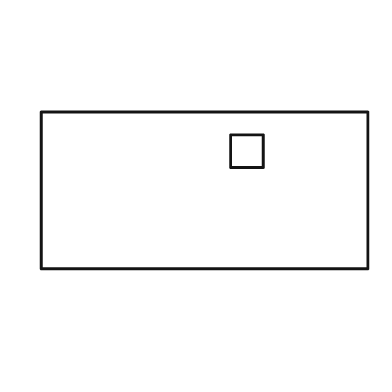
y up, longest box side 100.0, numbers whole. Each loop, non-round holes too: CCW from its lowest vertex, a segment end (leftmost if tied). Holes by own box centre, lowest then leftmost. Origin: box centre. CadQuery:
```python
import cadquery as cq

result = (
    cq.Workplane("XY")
    .moveTo(-50.0, -24.0)
    .lineTo(50.0, -24.0)
    .lineTo(50.0, 24.0)
    .lineTo(-50.0, 24.0)
    .close()
    .moveTo(8.0, 7.0)
    .lineTo(18.0, 7.0)
    .lineTo(18.0, 17.0)
    .lineTo(8.0, 17.0)
    .close()
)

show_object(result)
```